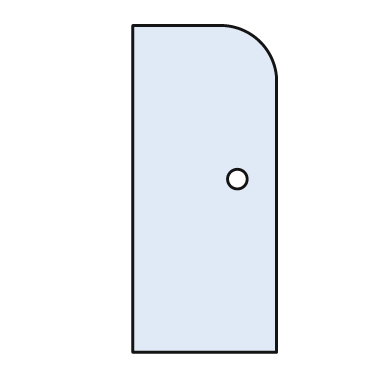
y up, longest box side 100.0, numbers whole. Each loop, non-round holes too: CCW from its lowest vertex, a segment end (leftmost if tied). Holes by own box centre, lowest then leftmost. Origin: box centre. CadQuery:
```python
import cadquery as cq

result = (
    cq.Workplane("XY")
    .moveTo(-22.0, -50.0)
    .lineTo(22.0, -50.0)
    .lineTo(22.0, 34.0)
    .threePointArc((17.0, 45.0), (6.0, 50.0))
    .lineTo(-22.0, 50.0)
    .close()
    .moveTo(10.0, 3.0)
    .circle(3.0)
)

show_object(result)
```